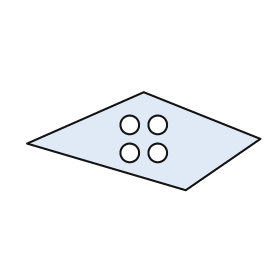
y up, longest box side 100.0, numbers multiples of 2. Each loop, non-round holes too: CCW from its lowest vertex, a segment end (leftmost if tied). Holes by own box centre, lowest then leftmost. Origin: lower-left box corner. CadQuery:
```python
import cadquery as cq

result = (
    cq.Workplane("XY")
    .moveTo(68.0, 0.0)
    .lineTo(100.0, 22.0)
    .lineTo(50.0, 42.0)
    .lineTo(0.0, 20.0)
    .close()
    .moveTo(44.0, 16.0)
    .circle(4.0)
    .moveTo(56.0, 16.0)
    .circle(4.0)
    .moveTo(44.0, 28.0)
    .circle(4.0)
    .moveTo(56.0, 28.0)
    .circle(4.0)
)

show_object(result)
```